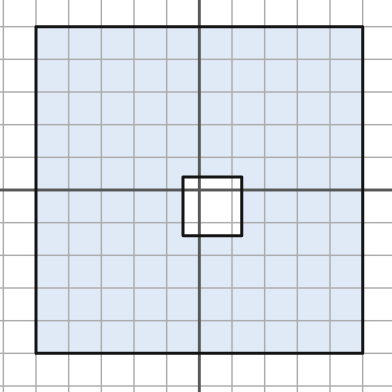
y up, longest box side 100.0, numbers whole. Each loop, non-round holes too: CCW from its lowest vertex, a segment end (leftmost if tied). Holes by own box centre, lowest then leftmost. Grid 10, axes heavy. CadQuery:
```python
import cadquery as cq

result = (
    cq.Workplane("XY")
    .moveTo(-50.0, -50.0)
    .lineTo(50.0, -50.0)
    .lineTo(50.0, 50.0)
    .lineTo(-50.0, 50.0)
    .close()
    .moveTo(-5.0, -14.0)
    .lineTo(13.0, -14.0)
    .lineTo(13.0, 4.0)
    .lineTo(-5.0, 4.0)
    .close()
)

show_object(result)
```